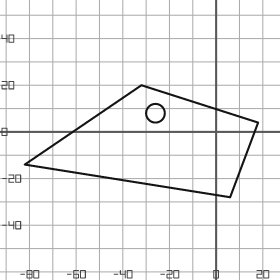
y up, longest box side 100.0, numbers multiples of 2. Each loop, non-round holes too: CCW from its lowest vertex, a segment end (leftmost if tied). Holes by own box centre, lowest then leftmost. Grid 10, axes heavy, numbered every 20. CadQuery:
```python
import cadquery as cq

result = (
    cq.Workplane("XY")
    .moveTo(6.0, -28.0)
    .lineTo(18.0, 4.0)
    .lineTo(-32.0, 20.0)
    .lineTo(-82.0, -14.0)
    .close()
    .moveTo(-26.0, 8.0)
    .circle(4.0)
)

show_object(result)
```